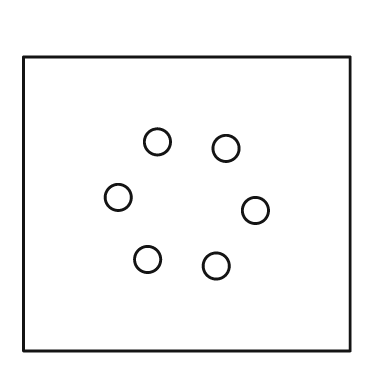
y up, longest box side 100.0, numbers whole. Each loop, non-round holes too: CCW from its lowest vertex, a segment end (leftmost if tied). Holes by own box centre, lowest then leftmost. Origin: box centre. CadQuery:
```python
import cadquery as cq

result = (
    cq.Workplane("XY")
    .moveTo(-50.0, -45.0)
    .lineTo(50.0, -45.0)
    .lineTo(50.0, 45.0)
    .lineTo(-50.0, 45.0)
    .close()
    .moveTo(9.0, -19.0)
    .circle(4.0)
    .moveTo(-12.0, -17.0)
    .circle(4.0)
    .moveTo(21.0, -2.0)
    .circle(4.0)
    .moveTo(-21.0, 2.0)
    .circle(4.0)
    .moveTo(12.0, 17.0)
    .circle(4.0)
    .moveTo(-9.0, 19.0)
    .circle(4.0)
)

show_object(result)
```